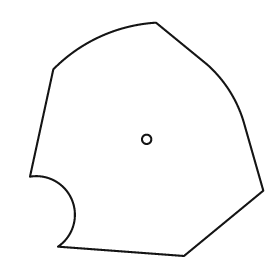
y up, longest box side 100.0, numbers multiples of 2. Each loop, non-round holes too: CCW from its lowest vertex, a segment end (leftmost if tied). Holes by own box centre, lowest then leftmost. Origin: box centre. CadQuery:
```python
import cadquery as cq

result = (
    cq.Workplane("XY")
    .moveTo(16.0, -50.0)
    .lineTo(50.0, -22.0)
    .lineTo(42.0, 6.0)
    .threePointArc((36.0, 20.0), (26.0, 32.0))
    .lineTo(4.0, 50.0)
    .threePointArc((-20.0, 44.0), (-40.0, 30.0))
    .lineTo(-50.0, -16.0)
    .threePointArc((-32.0, -26.0), (-38.0, -46.0))
    .close()
    .moveTo(0.0, 0.0)
    .circle(2.0)
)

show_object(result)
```